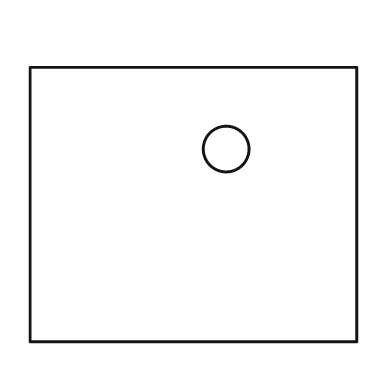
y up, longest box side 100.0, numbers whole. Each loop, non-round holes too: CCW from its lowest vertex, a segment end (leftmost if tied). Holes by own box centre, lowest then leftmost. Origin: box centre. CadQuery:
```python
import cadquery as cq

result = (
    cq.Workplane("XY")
    .moveTo(-50.0, -42.0)
    .lineTo(50.0, -42.0)
    .lineTo(50.0, 42.0)
    .lineTo(-50.0, 42.0)
    .close()
    .moveTo(10.0, 17.0)
    .circle(7.0)
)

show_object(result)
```